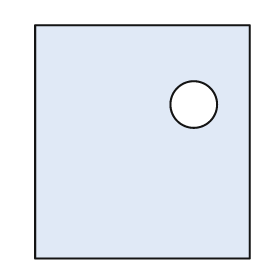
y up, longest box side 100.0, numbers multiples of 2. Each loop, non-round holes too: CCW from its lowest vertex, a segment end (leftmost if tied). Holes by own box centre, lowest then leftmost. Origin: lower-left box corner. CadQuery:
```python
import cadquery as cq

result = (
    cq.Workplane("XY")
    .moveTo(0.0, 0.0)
    .lineTo(92.0, 0.0)
    .lineTo(92.0, 100.0)
    .lineTo(0.0, 100.0)
    .close()
    .moveTo(68.0, 66.0)
    .circle(10.0)
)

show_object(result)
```